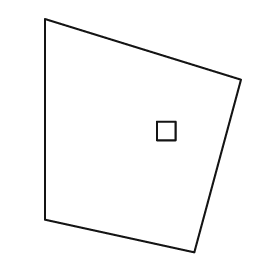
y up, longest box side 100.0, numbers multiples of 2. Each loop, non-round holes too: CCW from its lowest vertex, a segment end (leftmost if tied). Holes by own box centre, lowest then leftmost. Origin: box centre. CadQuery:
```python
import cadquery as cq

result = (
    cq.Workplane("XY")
    .moveTo(22.0, -50.0)
    .lineTo(42.0, 24.0)
    .lineTo(-42.0, 50.0)
    .lineTo(-42.0, -36.0)
    .close()
    .moveTo(6.0, -2.0)
    .lineTo(14.0, -2.0)
    .lineTo(14.0, 6.0)
    .lineTo(6.0, 6.0)
    .close()
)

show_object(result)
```